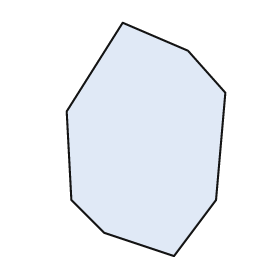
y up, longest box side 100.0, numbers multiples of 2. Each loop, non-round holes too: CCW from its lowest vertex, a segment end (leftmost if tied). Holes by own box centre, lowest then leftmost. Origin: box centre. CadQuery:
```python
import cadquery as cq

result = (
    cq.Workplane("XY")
    .moveTo(12.0, -50.0)
    .lineTo(30.0, -26.0)
    .lineTo(34.0, 20.0)
    .lineTo(18.0, 38.0)
    .lineTo(-10.0, 50.0)
    .lineTo(-34.0, 12.0)
    .lineTo(-32.0, -26.0)
    .lineTo(-18.0, -40.0)
    .close()
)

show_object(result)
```